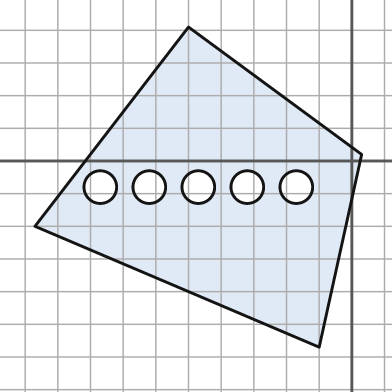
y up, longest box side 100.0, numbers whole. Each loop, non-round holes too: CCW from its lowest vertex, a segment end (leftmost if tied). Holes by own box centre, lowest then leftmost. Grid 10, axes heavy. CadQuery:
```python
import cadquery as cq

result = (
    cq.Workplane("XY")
    .moveTo(-10.0, -57.0)
    .lineTo(3.0, 2.0)
    .lineTo(-50.0, 41.0)
    .lineTo(-97.0, -20.0)
    .close()
    .moveTo(-77.0, -8.0)
    .circle(5.0)
    .moveTo(-62.0, -8.0)
    .circle(5.0)
    .moveTo(-47.0, -8.0)
    .circle(5.0)
    .moveTo(-32.0, -8.0)
    .circle(5.0)
    .moveTo(-17.0, -8.0)
    .circle(5.0)
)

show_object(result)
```